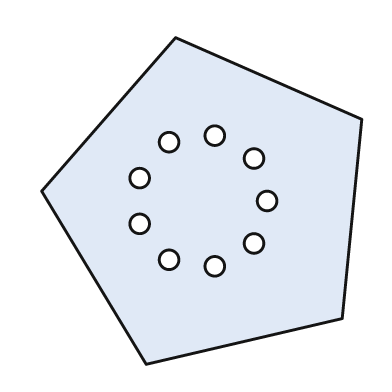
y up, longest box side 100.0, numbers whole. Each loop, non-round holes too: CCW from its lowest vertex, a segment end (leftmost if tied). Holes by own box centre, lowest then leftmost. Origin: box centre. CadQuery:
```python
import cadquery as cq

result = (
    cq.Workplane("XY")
    .moveTo(-17.0, -50.0)
    .lineTo(43.0, -36.0)
    .lineTo(49.0, 25.0)
    .lineTo(-8.0, 50.0)
    .lineTo(-49.0, 3.0)
    .close()
    .moveTo(4.0, -20.0)
    .circle(3.0)
    .moveTo(-10.0, -18.0)
    .circle(3.0)
    .moveTo(16.0, -13.0)
    .circle(3.0)
    .moveTo(-19.0, -7.0)
    .circle(3.0)
    .moveTo(20.0, 0.0)
    .circle(3.0)
    .moveTo(-19.0, 7.0)
    .circle(3.0)
    .moveTo(16.0, 13.0)
    .circle(3.0)
    .moveTo(-10.0, 18.0)
    .circle(3.0)
    .moveTo(4.0, 20.0)
    .circle(3.0)
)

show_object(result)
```